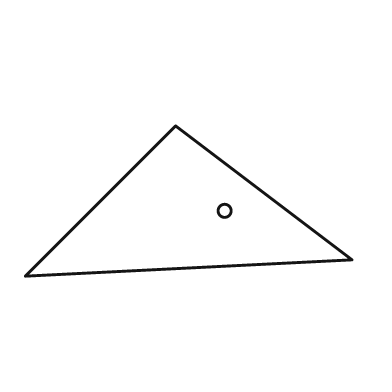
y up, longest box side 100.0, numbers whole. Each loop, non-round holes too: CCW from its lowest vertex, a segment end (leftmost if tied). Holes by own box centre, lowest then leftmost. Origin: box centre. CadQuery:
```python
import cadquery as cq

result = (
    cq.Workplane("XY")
    .moveTo(-50.0, -23.0)
    .lineTo(50.0, -18.0)
    .lineTo(-4.0, 23.0)
    .close()
    .moveTo(11.0, -3.0)
    .circle(2.0)
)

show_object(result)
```